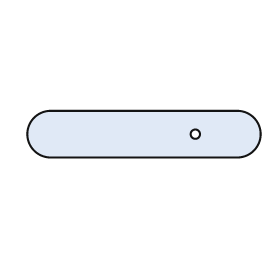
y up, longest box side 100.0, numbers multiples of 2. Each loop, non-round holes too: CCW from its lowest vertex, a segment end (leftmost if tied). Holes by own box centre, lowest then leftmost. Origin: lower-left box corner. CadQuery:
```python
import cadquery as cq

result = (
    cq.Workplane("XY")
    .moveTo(10.0, 0.0)
    .lineTo(90.0, 0.0)
    .threePointArc((100.0, 10.0), (90.0, 20.0))
    .lineTo(10.0, 20.0)
    .threePointArc((0.0, 10.0), (10.0, 0.0))
    .close()
    .moveTo(72.0, 10.0)
    .circle(2.0)
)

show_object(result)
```